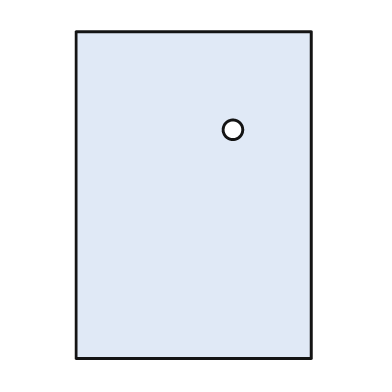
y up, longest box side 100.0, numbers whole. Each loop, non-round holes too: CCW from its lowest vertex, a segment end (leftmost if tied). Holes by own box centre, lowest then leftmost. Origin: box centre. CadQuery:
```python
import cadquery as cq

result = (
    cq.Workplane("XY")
    .moveTo(-36.0, -50.0)
    .lineTo(36.0, -50.0)
    .lineTo(36.0, 50.0)
    .lineTo(-36.0, 50.0)
    .close()
    .moveTo(12.0, 20.0)
    .circle(3.0)
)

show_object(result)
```